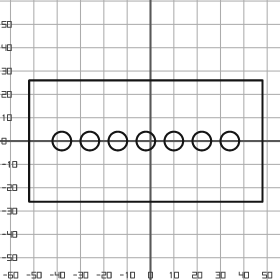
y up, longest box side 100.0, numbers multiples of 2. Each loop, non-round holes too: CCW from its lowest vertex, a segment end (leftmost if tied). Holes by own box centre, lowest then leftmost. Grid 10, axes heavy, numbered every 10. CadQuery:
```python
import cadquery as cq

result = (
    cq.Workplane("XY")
    .moveTo(-52.0, -26.0)
    .lineTo(48.0, -26.0)
    .lineTo(48.0, 26.0)
    .lineTo(-52.0, 26.0)
    .close()
    .moveTo(-38.0, 0.0)
    .circle(4.0)
    .moveTo(-26.0, 0.0)
    .circle(4.0)
    .moveTo(-14.0, 0.0)
    .circle(4.0)
    .moveTo(-2.0, 0.0)
    .circle(4.0)
    .moveTo(10.0, 0.0)
    .circle(4.0)
    .moveTo(22.0, 0.0)
    .circle(4.0)
    .moveTo(34.0, 0.0)
    .circle(4.0)
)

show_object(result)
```